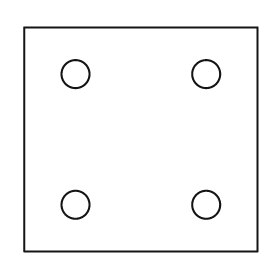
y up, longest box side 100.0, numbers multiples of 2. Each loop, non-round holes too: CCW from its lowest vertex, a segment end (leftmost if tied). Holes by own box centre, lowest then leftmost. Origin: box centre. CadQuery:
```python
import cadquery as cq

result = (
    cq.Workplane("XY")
    .moveTo(-50.0, -48.0)
    .lineTo(50.0, -48.0)
    .lineTo(50.0, 48.0)
    .lineTo(-50.0, 48.0)
    .close()
    .moveTo(-28.0, -28.0)
    .circle(6.0)
    .moveTo(28.0, -28.0)
    .circle(6.0)
    .moveTo(-28.0, 28.0)
    .circle(6.0)
    .moveTo(28.0, 28.0)
    .circle(6.0)
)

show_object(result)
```